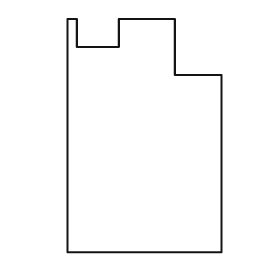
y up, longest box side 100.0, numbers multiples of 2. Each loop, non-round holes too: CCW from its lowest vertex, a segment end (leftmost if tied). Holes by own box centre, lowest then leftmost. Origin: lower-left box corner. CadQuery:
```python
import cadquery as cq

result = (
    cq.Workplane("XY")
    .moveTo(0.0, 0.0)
    .lineTo(66.0, 0.0)
    .lineTo(66.0, 76.0)
    .lineTo(46.0, 76.0)
    .lineTo(46.0, 100.0)
    .lineTo(22.0, 100.0)
    .lineTo(22.0, 88.0)
    .lineTo(4.0, 88.0)
    .lineTo(4.0, 100.0)
    .lineTo(0.0, 100.0)
    .close()
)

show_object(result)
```